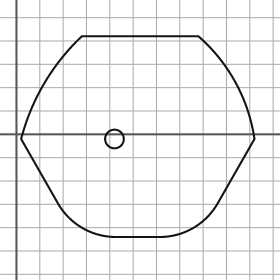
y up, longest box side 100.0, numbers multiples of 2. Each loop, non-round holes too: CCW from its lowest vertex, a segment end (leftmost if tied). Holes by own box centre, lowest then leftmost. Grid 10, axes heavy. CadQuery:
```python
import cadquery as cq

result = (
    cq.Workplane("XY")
    .moveTo(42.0, -44.0)
    .lineTo(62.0, -44.0)
    .threePointArc((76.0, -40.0), (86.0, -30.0))
    .lineTo(102.0, -2.0)
    .threePointArc((94.0, 22.0), (78.0, 42.0))
    .lineTo(28.0, 42.0)
    .threePointArc((12.0, 22.0), (2.0, -2.0))
    .lineTo(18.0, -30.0)
    .threePointArc((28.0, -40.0), (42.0, -44.0))
    .close()
    .moveTo(42.0, -2.0)
    .circle(4.0)
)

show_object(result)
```